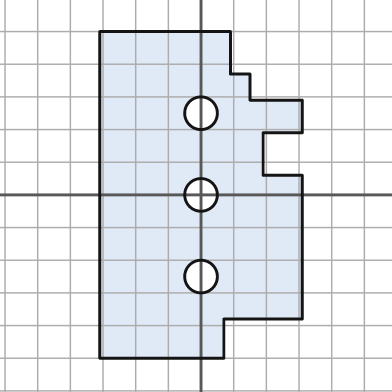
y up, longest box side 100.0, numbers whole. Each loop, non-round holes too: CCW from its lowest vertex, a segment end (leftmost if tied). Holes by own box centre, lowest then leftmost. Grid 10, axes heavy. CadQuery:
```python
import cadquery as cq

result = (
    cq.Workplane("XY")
    .moveTo(-31.0, -50.0)
    .lineTo(7.0, -50.0)
    .lineTo(7.0, -38.0)
    .lineTo(31.0, -38.0)
    .lineTo(31.0, 6.0)
    .lineTo(19.0, 6.0)
    .lineTo(19.0, 19.0)
    .lineTo(31.0, 19.0)
    .lineTo(31.0, 29.0)
    .lineTo(15.0, 29.0)
    .lineTo(15.0, 37.0)
    .lineTo(9.0, 37.0)
    .lineTo(9.0, 50.0)
    .lineTo(-31.0, 50.0)
    .close()
    .moveTo(0.0, -25.0)
    .circle(5.0)
    .moveTo(0.0, 0.0)
    .circle(5.0)
    .moveTo(0.0, 25.0)
    .circle(5.0)
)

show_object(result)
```